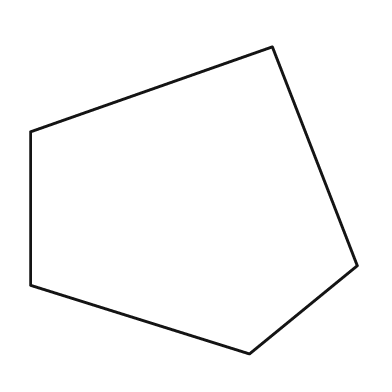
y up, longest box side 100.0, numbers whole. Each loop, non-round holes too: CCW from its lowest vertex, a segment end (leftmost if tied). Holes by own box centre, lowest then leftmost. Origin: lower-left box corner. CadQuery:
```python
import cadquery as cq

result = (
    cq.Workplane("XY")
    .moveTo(67.0, 0.0)
    .lineTo(100.0, 27.0)
    .lineTo(74.0, 94.0)
    .lineTo(0.0, 68.0)
    .lineTo(0.0, 21.0)
    .close()
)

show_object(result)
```